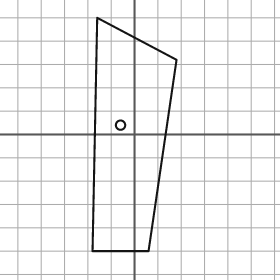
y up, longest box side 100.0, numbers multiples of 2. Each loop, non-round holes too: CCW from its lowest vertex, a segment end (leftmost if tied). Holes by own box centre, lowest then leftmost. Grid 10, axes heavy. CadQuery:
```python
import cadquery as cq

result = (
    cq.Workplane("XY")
    .moveTo(-18.0, -50.0)
    .lineTo(6.0, -50.0)
    .lineTo(18.0, 32.0)
    .lineTo(-16.0, 50.0)
    .close()
    .moveTo(-6.0, 4.0)
    .circle(2.0)
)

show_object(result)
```